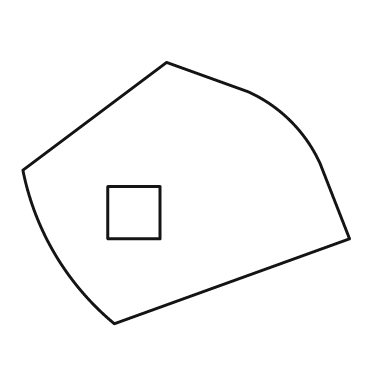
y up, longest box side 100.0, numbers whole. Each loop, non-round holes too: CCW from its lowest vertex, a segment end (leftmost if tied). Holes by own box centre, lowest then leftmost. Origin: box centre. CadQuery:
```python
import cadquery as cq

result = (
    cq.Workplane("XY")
    .moveTo(-22.0, -40.0)
    .lineTo(50.0, -14.0)
    .lineTo(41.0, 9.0)
    .threePointArc((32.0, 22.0), (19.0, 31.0))
    .lineTo(-6.0, 40.0)
    .lineTo(-50.0, 7.0)
    .threePointArc((-40.0, -19.0), (-22.0, -40.0))
    .close()
    .moveTo(-24.0, -14.0)
    .lineTo(-8.0, -14.0)
    .lineTo(-8.0, 2.0)
    .lineTo(-24.0, 2.0)
    .close()
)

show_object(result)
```